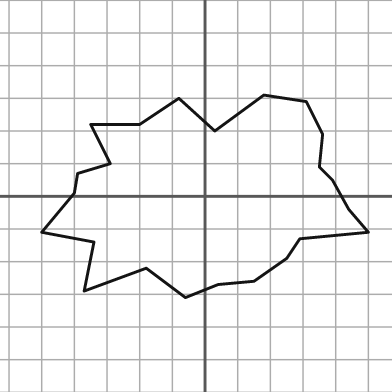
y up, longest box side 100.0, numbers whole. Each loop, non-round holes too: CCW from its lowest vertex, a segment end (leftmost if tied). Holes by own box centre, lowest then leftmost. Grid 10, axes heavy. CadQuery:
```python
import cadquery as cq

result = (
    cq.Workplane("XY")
    .moveTo(-6.0, -31.0)
    .lineTo(4.0, -27.0)
    .lineTo(15.0, -26.0)
    .lineTo(25.0, -19.0)
    .lineTo(29.0, -13.0)
    .lineTo(50.0, -11.0)
    .lineTo(44.0, -4.0)
    .lineTo(39.0, 5.0)
    .lineTo(35.0, 9.0)
    .lineTo(36.0, 19.0)
    .lineTo(31.0, 29.0)
    .lineTo(18.0, 31.0)
    .lineTo(3.0, 20.0)
    .lineTo(-8.0, 30.0)
    .lineTo(-20.0, 22.0)
    .lineTo(-35.0, 22.0)
    .lineTo(-29.0, 10.0)
    .lineTo(-39.0, 7.0)
    .lineTo(-40.0, 1.0)
    .lineTo(-50.0, -11.0)
    .lineTo(-34.0, -14.0)
    .lineTo(-37.0, -29.0)
    .lineTo(-18.0, -22.0)
    .close()
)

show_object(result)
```